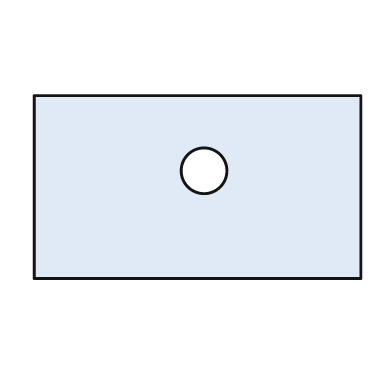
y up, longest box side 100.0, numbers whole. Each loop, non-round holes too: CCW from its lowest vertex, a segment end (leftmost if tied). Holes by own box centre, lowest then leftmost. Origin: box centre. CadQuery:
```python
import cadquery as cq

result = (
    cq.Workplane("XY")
    .moveTo(-50.0, -28.0)
    .lineTo(50.0, -28.0)
    .lineTo(50.0, 28.0)
    .lineTo(-50.0, 28.0)
    .close()
    .moveTo(2.0, 5.0)
    .circle(7.0)
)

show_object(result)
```